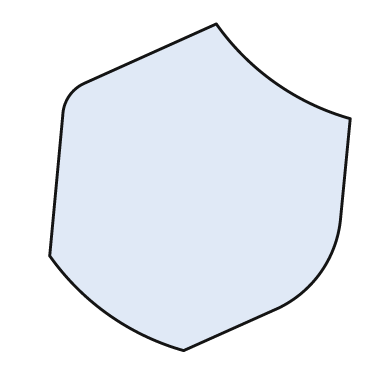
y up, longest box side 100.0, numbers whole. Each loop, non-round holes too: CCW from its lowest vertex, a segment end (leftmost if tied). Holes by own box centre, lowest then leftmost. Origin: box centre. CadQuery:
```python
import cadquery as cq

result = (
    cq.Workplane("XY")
    .moveTo(-5.0, -50.0)
    .lineTo(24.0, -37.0)
    .threePointArc((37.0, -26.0), (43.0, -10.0))
    .lineTo(46.0, 21.0)
    .threePointArc((23.0, 32.0), (5.0, 50.0))
    .lineTo(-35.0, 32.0)
    .threePointArc((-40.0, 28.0), (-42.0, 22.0))
    .lineTo(-46.0, -21.0)
    .threePointArc((-28.0, -39.0), (-5.0, -50.0))
    .close()
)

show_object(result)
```